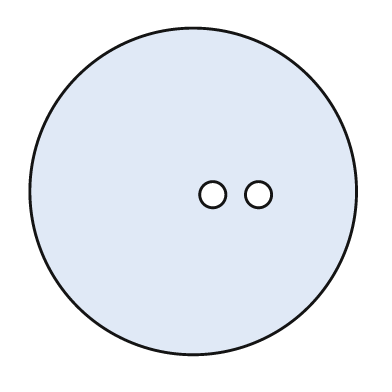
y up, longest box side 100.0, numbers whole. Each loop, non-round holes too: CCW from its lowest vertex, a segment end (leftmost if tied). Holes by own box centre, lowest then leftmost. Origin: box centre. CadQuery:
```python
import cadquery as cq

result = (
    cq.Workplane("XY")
    .moveTo(0.0, 0.0)
    .circle(50.0)
    .moveTo(6.0, -1.0)
    .circle(4.0)
    .moveTo(20.0, -1.0)
    .circle(4.0)
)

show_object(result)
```